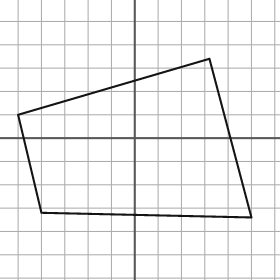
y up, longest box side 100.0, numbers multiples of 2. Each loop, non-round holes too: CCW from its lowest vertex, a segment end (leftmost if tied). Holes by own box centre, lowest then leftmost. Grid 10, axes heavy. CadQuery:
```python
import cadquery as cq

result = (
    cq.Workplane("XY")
    .moveTo(50.0, -34.0)
    .lineTo(32.0, 34.0)
    .lineTo(-50.0, 10.0)
    .lineTo(-40.0, -32.0)
    .close()
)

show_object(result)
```